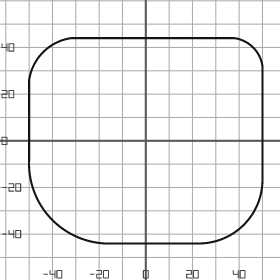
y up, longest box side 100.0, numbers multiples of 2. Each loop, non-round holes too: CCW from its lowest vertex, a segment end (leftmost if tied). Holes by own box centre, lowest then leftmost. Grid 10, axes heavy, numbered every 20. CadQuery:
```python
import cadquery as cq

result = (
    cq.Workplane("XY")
    .moveTo(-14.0, -44.0)
    .lineTo(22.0, -44.0)
    .threePointArc((42.0, -36.0), (50.0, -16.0))
    .lineTo(50.0, 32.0)
    .threePointArc((46.0, 40.0), (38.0, 44.0))
    .lineTo(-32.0, 44.0)
    .threePointArc((-44.0, 38.0), (-50.0, 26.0))
    .lineTo(-50.0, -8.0)
    .threePointArc((-40.0, -34.0), (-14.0, -44.0))
    .close()
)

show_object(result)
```